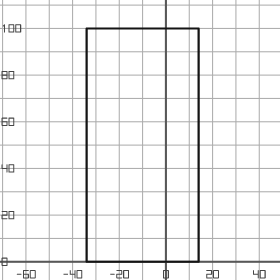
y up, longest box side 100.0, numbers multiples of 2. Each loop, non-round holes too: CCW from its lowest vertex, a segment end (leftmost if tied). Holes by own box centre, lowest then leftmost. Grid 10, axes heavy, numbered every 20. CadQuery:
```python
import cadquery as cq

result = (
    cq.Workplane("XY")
    .moveTo(-34.0, 0.0)
    .lineTo(14.0, 0.0)
    .lineTo(14.0, 100.0)
    .lineTo(-34.0, 100.0)
    .close()
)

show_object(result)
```